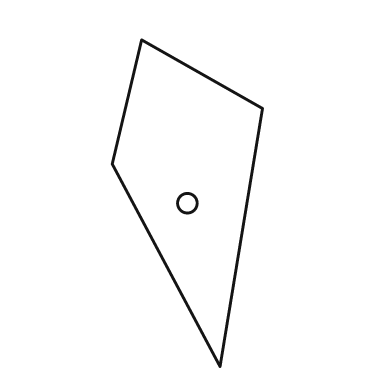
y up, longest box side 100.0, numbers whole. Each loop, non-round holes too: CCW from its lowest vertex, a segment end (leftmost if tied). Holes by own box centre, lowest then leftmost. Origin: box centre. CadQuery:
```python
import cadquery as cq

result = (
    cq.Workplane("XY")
    .moveTo(10.0, -50.0)
    .lineTo(23.0, 29.0)
    .lineTo(-14.0, 50.0)
    .lineTo(-23.0, 12.0)
    .close()
    .moveTo(0.0, 0.0)
    .circle(3.0)
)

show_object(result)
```